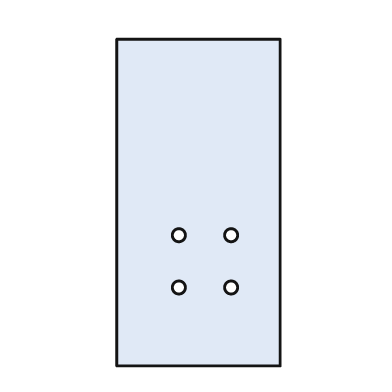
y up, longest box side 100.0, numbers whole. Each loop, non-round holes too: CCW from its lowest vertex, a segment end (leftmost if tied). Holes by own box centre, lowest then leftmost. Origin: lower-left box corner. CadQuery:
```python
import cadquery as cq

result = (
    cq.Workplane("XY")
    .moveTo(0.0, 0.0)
    .lineTo(50.0, 0.0)
    .lineTo(50.0, 100.0)
    .lineTo(0.0, 100.0)
    .close()
    .moveTo(19.0, 24.0)
    .circle(2.0)
    .moveTo(35.0, 24.0)
    .circle(2.0)
    .moveTo(19.0, 40.0)
    .circle(2.0)
    .moveTo(35.0, 40.0)
    .circle(2.0)
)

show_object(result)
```